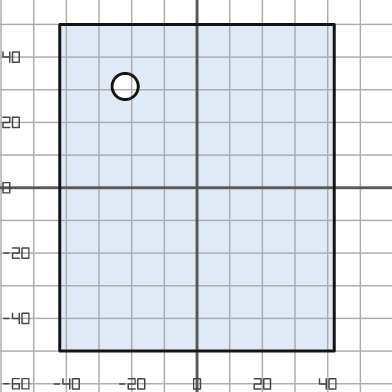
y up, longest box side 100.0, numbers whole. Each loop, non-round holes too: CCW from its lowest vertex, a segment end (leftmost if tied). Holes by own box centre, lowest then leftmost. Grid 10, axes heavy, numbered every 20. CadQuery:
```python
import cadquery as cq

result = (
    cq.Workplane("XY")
    .moveTo(-42.0, -50.0)
    .lineTo(42.0, -50.0)
    .lineTo(42.0, 50.0)
    .lineTo(-42.0, 50.0)
    .close()
    .moveTo(-22.0, 31.0)
    .circle(4.0)
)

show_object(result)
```